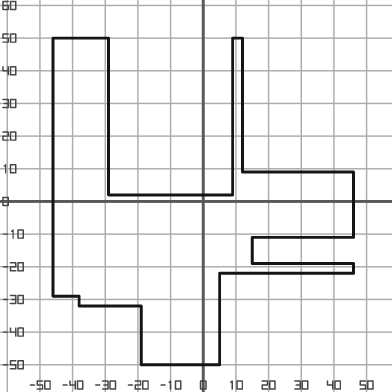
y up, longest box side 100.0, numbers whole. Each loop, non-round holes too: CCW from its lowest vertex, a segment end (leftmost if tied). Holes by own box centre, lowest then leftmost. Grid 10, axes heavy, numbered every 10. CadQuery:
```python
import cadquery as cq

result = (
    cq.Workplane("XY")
    .moveTo(-19.0, -50.0)
    .lineTo(5.0, -50.0)
    .lineTo(5.0, -22.0)
    .lineTo(46.0, -22.0)
    .lineTo(46.0, -19.0)
    .lineTo(15.0, -19.0)
    .lineTo(15.0, -11.0)
    .lineTo(46.0, -11.0)
    .lineTo(46.0, 9.0)
    .lineTo(12.0, 9.0)
    .lineTo(12.0, 50.0)
    .lineTo(9.0, 50.0)
    .lineTo(9.0, 2.0)
    .lineTo(-29.0, 2.0)
    .lineTo(-29.0, 50.0)
    .lineTo(-46.0, 50.0)
    .lineTo(-46.0, -29.0)
    .lineTo(-38.0, -29.0)
    .lineTo(-38.0, -32.0)
    .lineTo(-19.0, -32.0)
    .close()
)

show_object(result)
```